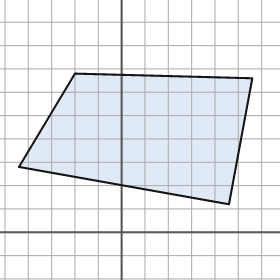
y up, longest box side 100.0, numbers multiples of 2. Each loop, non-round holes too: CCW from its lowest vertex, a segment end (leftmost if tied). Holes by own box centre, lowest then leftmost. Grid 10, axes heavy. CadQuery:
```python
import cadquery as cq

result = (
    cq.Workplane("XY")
    .moveTo(46.0, 12.0)
    .lineTo(56.0, 66.0)
    .lineTo(-20.0, 68.0)
    .lineTo(-44.0, 28.0)
    .close()
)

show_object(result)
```